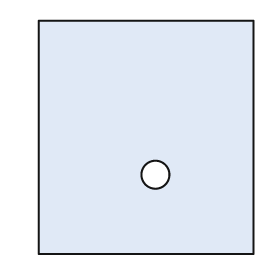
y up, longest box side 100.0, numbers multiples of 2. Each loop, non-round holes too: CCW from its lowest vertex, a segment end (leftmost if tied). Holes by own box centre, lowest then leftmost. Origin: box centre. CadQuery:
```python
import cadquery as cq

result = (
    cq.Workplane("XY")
    .moveTo(-46.0, -50.0)
    .lineTo(46.0, -50.0)
    .lineTo(46.0, 50.0)
    .lineTo(-46.0, 50.0)
    .close()
    .moveTo(4.0, -16.0)
    .circle(6.0)
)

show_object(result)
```